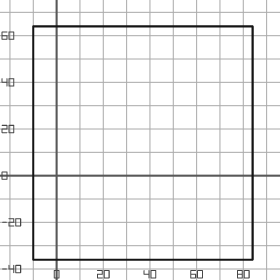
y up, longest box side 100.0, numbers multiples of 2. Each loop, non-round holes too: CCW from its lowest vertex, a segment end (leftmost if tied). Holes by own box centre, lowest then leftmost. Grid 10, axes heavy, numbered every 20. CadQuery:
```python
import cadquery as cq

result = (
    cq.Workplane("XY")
    .moveTo(-10.0, -36.0)
    .lineTo(84.0, -36.0)
    .lineTo(84.0, 64.0)
    .lineTo(-10.0, 64.0)
    .close()
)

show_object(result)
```